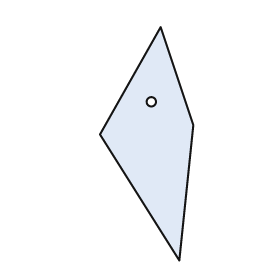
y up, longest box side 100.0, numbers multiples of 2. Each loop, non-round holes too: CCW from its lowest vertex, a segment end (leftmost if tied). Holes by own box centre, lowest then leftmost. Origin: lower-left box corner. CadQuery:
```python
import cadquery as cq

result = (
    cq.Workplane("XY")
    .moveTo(34.0, 0.0)
    .lineTo(40.0, 58.0)
    .lineTo(26.0, 100.0)
    .lineTo(0.0, 54.0)
    .close()
    .moveTo(22.0, 68.0)
    .circle(2.0)
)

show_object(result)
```